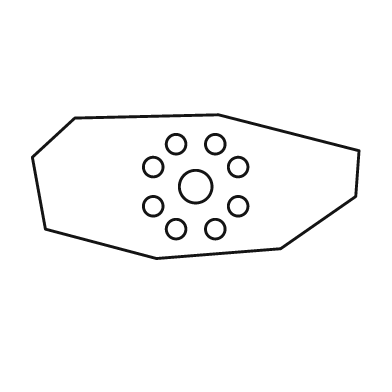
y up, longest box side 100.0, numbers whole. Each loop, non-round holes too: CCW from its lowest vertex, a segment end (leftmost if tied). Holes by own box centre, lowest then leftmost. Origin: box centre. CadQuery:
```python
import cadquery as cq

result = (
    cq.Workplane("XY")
    .moveTo(-12.0, -22.0)
    .lineTo(26.0, -19.0)
    .lineTo(49.0, -3.0)
    .lineTo(50.0, 11.0)
    .lineTo(7.0, 22.0)
    .lineTo(-37.0, 21.0)
    .lineTo(-50.0, 9.0)
    .lineTo(-46.0, -13.0)
    .close()
    .moveTo(-6.0, -13.0)
    .circle(3.0)
    .moveTo(6.0, -13.0)
    .circle(3.0)
    .moveTo(-13.0, -6.0)
    .circle(3.0)
    .moveTo(13.0, -6.0)
    .circle(3.0)
    .moveTo(0.0, 0.0)
    .circle(5.0)
    .moveTo(-13.0, 6.0)
    .circle(3.0)
    .moveTo(13.0, 6.0)
    .circle(3.0)
    .moveTo(-6.0, 13.0)
    .circle(3.0)
    .moveTo(6.0, 13.0)
    .circle(3.0)
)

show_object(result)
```